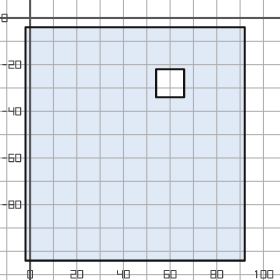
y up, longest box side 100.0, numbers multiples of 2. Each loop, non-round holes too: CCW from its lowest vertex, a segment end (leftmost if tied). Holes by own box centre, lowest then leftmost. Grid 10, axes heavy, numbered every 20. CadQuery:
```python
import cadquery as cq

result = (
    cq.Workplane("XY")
    .moveTo(-2.0, -104.0)
    .lineTo(92.0, -104.0)
    .lineTo(92.0, -4.0)
    .lineTo(-2.0, -4.0)
    .close()
    .moveTo(54.0, -34.0)
    .lineTo(66.0, -34.0)
    .lineTo(66.0, -22.0)
    .lineTo(54.0, -22.0)
    .close()
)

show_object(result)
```